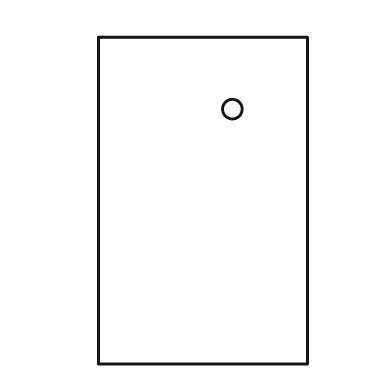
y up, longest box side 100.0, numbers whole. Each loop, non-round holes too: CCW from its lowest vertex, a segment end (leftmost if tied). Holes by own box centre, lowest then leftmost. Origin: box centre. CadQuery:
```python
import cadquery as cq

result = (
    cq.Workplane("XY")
    .moveTo(-32.0, -50.0)
    .lineTo(32.0, -50.0)
    .lineTo(32.0, 50.0)
    .lineTo(-32.0, 50.0)
    .close()
    .moveTo(9.0, 28.0)
    .circle(3.0)
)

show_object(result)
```